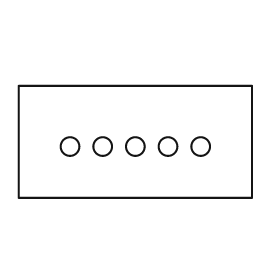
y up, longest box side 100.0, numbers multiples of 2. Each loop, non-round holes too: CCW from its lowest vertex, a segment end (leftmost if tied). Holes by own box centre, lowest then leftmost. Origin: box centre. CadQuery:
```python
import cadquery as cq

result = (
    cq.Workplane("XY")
    .moveTo(-50.0, -24.0)
    .lineTo(50.0, -24.0)
    .lineTo(50.0, 24.0)
    .lineTo(-50.0, 24.0)
    .close()
    .moveTo(-28.0, -2.0)
    .circle(4.0)
    .moveTo(-14.0, -2.0)
    .circle(4.0)
    .moveTo(0.0, -2.0)
    .circle(4.0)
    .moveTo(14.0, -2.0)
    .circle(4.0)
    .moveTo(28.0, -2.0)
    .circle(4.0)
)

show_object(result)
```